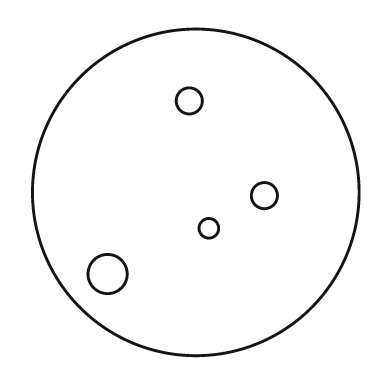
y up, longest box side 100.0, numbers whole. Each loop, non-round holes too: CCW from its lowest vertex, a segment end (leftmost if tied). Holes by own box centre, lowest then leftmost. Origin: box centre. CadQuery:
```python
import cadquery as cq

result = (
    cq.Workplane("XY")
    .moveTo(0.0, 0.0)
    .circle(50.0)
    .moveTo(-27.0, -25.0)
    .circle(6.0)
    .moveTo(4.0, -11.0)
    .circle(3.0)
    .moveTo(21.0, -1.0)
    .circle(4.0)
    .moveTo(-2.0, 28.0)
    .circle(4.0)
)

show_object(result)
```